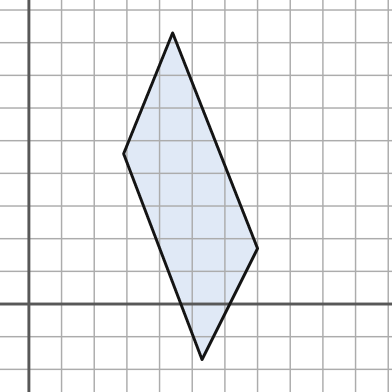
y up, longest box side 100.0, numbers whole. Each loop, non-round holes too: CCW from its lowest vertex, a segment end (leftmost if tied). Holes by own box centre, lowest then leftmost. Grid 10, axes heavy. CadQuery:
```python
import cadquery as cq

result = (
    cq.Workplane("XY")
    .moveTo(53.0, -17.0)
    .lineTo(70.0, 17.0)
    .lineTo(44.0, 83.0)
    .lineTo(29.0, 46.0)
    .close()
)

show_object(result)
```